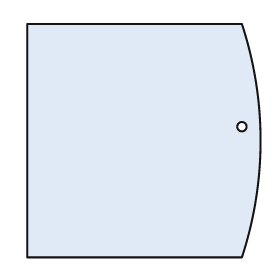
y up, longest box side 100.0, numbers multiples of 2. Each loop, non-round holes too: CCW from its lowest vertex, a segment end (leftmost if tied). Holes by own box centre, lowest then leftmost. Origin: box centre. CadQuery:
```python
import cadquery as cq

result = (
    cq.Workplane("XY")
    .moveTo(-50.0, -50.0)
    .lineTo(42.0, -50.0)
    .threePointArc((50.0, 0.0), (42.0, 50.0))
    .lineTo(-50.0, 50.0)
    .close()
    .moveTo(42.0, 6.0)
    .circle(2.0)
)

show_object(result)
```